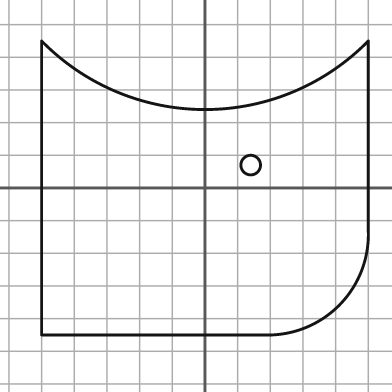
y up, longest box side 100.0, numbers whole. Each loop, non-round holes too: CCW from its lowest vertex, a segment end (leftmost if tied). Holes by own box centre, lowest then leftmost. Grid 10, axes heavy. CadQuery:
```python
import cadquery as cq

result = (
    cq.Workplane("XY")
    .moveTo(-50.0, -45.0)
    .lineTo(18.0, -45.0)
    .threePointArc((41.0, -36.0), (50.0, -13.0))
    .lineTo(50.0, 45.0)
    .threePointArc((0.0, 24.0), (-50.0, 45.0))
    .close()
    .moveTo(14.0, 7.0)
    .circle(3.0)
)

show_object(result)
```